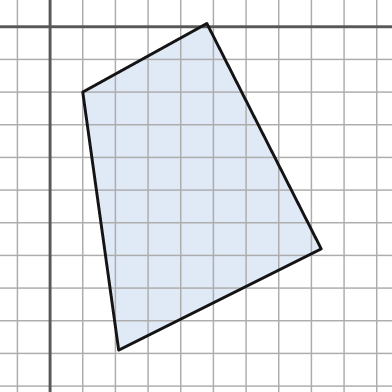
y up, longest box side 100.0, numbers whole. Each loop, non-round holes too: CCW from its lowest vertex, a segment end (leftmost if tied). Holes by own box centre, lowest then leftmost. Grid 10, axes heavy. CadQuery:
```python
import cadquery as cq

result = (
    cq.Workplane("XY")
    .moveTo(21.0, -99.0)
    .lineTo(83.0, -68.0)
    .lineTo(48.0, 1.0)
    .lineTo(10.0, -20.0)
    .close()
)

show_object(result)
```